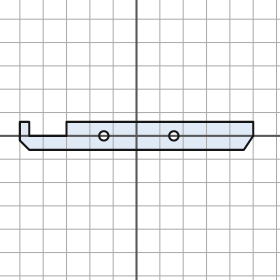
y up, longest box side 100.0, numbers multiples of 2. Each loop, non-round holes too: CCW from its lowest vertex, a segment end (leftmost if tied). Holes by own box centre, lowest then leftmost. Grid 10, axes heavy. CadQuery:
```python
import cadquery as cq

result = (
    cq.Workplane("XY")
    .moveTo(-46.0, -6.0)
    .lineTo(46.0, -6.0)
    .lineTo(50.0, 0.0)
    .lineTo(50.0, 6.0)
    .lineTo(-30.0, 6.0)
    .lineTo(-30.0, 0.0)
    .lineTo(-46.0, 0.0)
    .lineTo(-46.0, 6.0)
    .lineTo(-50.0, 6.0)
    .lineTo(-50.0, -2.0)
    .close()
    .moveTo(-14.0, 0.0)
    .circle(2.0)
    .moveTo(16.0, 0.0)
    .circle(2.0)
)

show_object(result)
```